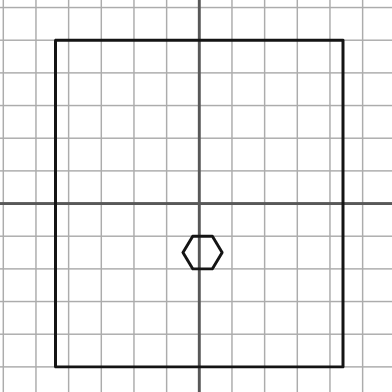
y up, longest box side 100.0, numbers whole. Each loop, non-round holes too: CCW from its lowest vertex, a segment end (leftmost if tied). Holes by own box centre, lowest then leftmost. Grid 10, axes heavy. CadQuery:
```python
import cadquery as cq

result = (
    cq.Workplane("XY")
    .moveTo(-44.0, -50.0)
    .lineTo(44.0, -50.0)
    .lineTo(44.0, 50.0)
    .lineTo(-44.0, 50.0)
    .close()
    .moveTo(-2.0, -20.0)
    .lineTo(4.0, -20.0)
    .lineTo(7.0, -15.0)
    .lineTo(4.0, -10.0)
    .lineTo(-2.0, -10.0)
    .lineTo(-5.0, -15.0)
    .close()
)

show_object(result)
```